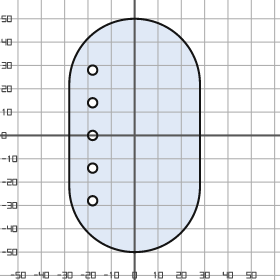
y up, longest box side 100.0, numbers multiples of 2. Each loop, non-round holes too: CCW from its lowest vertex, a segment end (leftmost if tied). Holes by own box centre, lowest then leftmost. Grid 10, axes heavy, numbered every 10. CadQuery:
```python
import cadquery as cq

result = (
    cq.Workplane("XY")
    .moveTo(-28.0, -22.0)
    .threePointArc((0.0, -50.0), (28.0, -22.0))
    .lineTo(28.0, 22.0)
    .threePointArc((0.0, 50.0), (-28.0, 22.0))
    .close()
    .moveTo(-18.0, -28.0)
    .circle(2.0)
    .moveTo(-18.0, -14.0)
    .circle(2.0)
    .moveTo(-18.0, 0.0)
    .circle(2.0)
    .moveTo(-18.0, 14.0)
    .circle(2.0)
    .moveTo(-18.0, 28.0)
    .circle(2.0)
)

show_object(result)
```